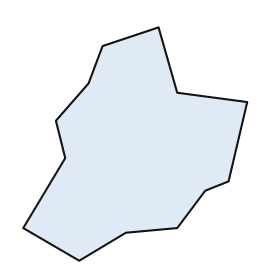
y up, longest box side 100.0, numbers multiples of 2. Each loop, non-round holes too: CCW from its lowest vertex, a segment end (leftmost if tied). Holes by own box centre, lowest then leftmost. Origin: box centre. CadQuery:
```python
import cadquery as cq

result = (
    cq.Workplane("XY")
    .moveTo(-24.0, -50.0)
    .lineTo(-4.0, -38.0)
    .lineTo(18.0, -36.0)
    .lineTo(30.0, -20.0)
    .lineTo(40.0, -16.0)
    .lineTo(48.0, 18.0)
    .lineTo(18.0, 22.0)
    .lineTo(10.0, 50.0)
    .lineTo(-14.0, 42.0)
    .lineTo(-20.0, 26.0)
    .lineTo(-34.0, 10.0)
    .lineTo(-30.0, -6.0)
    .lineTo(-48.0, -36.0)
    .close()
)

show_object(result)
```